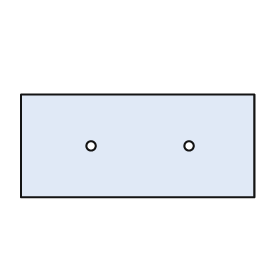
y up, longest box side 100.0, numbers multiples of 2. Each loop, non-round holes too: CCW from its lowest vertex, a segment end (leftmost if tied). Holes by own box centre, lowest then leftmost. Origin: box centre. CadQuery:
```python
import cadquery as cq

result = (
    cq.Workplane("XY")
    .moveTo(-50.0, -22.0)
    .lineTo(50.0, -22.0)
    .lineTo(50.0, 22.0)
    .lineTo(-50.0, 22.0)
    .close()
    .moveTo(-20.0, 0.0)
    .circle(2.0)
    .moveTo(22.0, 0.0)
    .circle(2.0)
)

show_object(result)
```